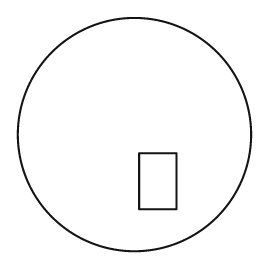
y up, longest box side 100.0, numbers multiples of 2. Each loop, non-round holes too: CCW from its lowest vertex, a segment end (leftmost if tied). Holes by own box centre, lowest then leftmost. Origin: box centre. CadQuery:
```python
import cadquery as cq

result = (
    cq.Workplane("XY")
    .moveTo(0.0, 0.0)
    .circle(50.0)
    .moveTo(2.0, -32.0)
    .lineTo(18.0, -32.0)
    .lineTo(18.0, -8.0)
    .lineTo(2.0, -8.0)
    .close()
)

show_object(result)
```